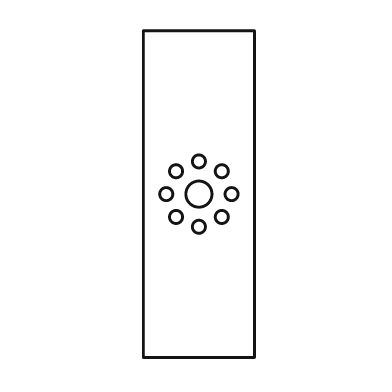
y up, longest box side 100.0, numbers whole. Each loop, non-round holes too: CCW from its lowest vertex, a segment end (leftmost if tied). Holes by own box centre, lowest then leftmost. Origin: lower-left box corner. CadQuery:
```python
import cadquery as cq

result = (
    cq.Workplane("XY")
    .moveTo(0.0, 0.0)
    .lineTo(34.0, 0.0)
    .lineTo(34.0, 100.0)
    .lineTo(0.0, 100.0)
    .close()
    .moveTo(17.0, 40.0)
    .circle(2.0)
    .moveTo(10.0, 43.0)
    .circle(2.0)
    .moveTo(24.0, 43.0)
    .circle(2.0)
    .moveTo(7.0, 50.0)
    .circle(2.0)
    .moveTo(17.0, 50.0)
    .circle(4.0)
    .moveTo(27.0, 50.0)
    .circle(2.0)
    .moveTo(10.0, 57.0)
    .circle(2.0)
    .moveTo(24.0, 57.0)
    .circle(2.0)
    .moveTo(17.0, 60.0)
    .circle(2.0)
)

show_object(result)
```